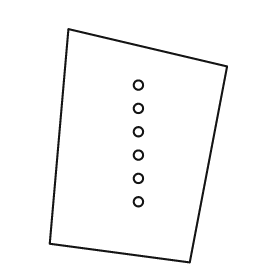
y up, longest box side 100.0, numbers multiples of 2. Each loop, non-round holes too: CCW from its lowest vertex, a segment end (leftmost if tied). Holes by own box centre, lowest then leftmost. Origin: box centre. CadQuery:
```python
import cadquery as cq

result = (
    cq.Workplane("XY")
    .moveTo(22.0, -50.0)
    .lineTo(38.0, 34.0)
    .lineTo(-30.0, 50.0)
    .lineTo(-38.0, -42.0)
    .close()
    .moveTo(0.0, -24.0)
    .circle(2.0)
    .moveTo(0.0, -14.0)
    .circle(2.0)
    .moveTo(0.0, -4.0)
    .circle(2.0)
    .moveTo(0.0, 6.0)
    .circle(2.0)
    .moveTo(0.0, 16.0)
    .circle(2.0)
    .moveTo(0.0, 26.0)
    .circle(2.0)
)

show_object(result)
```